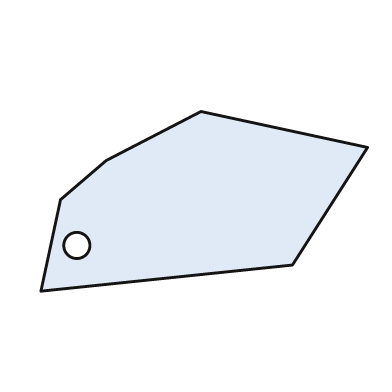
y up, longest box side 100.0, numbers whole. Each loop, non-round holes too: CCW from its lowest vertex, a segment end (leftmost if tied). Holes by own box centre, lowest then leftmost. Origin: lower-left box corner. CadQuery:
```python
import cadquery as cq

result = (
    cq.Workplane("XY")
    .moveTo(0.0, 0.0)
    .lineTo(77.0, 8.0)
    .lineTo(100.0, 44.0)
    .lineTo(49.0, 55.0)
    .lineTo(20.0, 40.0)
    .lineTo(6.0, 28.0)
    .close()
    .moveTo(11.0, 14.0)
    .circle(4.0)
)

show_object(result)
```